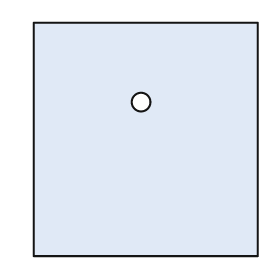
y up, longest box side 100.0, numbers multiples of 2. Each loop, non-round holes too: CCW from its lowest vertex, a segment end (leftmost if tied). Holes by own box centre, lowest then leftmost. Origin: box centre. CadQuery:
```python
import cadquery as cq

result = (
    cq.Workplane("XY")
    .moveTo(-48.0, -50.0)
    .lineTo(48.0, -50.0)
    .lineTo(48.0, 50.0)
    .lineTo(-48.0, 50.0)
    .close()
    .moveTo(-2.0, 16.0)
    .circle(4.0)
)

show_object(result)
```